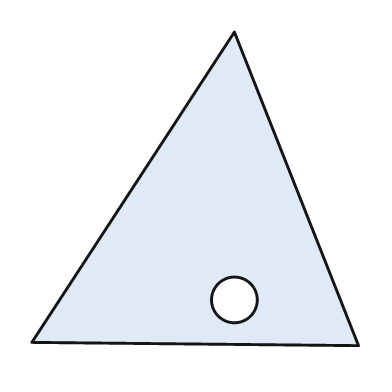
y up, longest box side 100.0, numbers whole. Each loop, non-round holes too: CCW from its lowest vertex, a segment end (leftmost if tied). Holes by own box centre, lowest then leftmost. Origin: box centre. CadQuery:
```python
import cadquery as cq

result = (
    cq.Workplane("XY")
    .moveTo(50.0, -48.0)
    .lineTo(12.0, 48.0)
    .lineTo(-50.0, -47.0)
    .close()
    .moveTo(12.0, -34.0)
    .circle(7.0)
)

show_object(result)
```